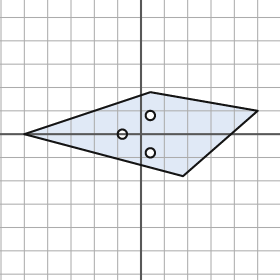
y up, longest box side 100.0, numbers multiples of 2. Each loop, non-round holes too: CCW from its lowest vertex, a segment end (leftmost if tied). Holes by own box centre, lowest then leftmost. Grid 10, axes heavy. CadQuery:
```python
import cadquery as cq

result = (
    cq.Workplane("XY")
    .moveTo(18.0, -18.0)
    .lineTo(50.0, 10.0)
    .lineTo(4.0, 18.0)
    .lineTo(-50.0, 0.0)
    .close()
    .moveTo(4.0, -8.0)
    .circle(2.0)
    .moveTo(-8.0, 0.0)
    .circle(2.0)
    .moveTo(4.0, 8.0)
    .circle(2.0)
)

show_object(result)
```